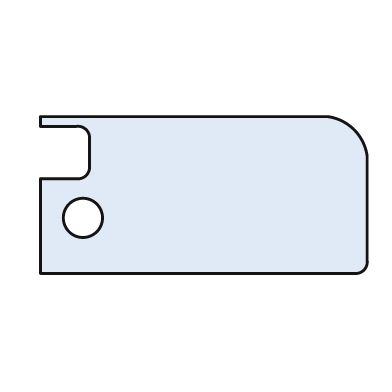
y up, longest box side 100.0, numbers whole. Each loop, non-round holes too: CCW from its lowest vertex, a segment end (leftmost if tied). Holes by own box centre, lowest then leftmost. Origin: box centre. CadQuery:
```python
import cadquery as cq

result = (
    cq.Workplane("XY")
    .moveTo(-50.0, -24.0)
    .lineTo(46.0, -24.0)
    .threePointArc((49.0, -23.0), (50.0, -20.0))
    .lineTo(50.0, 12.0)
    .threePointArc((46.0, 20.0), (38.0, 24.0))
    .lineTo(-50.0, 24.0)
    .lineTo(-50.0, 21.0)
    .lineTo(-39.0, 21.0)
    .threePointArc((-36.0, 20.0), (-35.0, 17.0))
    .lineTo(-35.0, 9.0)
    .threePointArc((-36.0, 6.0), (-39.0, 5.0))
    .lineTo(-50.0, 5.0)
    .close()
    .moveTo(-37.0, -7.0)
    .circle(6.0)
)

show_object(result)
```